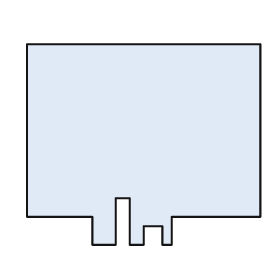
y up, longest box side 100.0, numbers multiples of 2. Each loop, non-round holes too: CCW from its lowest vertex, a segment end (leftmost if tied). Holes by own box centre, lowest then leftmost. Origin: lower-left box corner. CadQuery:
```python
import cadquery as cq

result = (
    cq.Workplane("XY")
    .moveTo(28.0, 0.0)
    .lineTo(38.0, 0.0)
    .lineTo(38.0, 20.0)
    .lineTo(44.0, 20.0)
    .lineTo(44.0, 0.0)
    .lineTo(50.0, 0.0)
    .lineTo(50.0, 8.0)
    .lineTo(58.0, 8.0)
    .lineTo(58.0, 0.0)
    .lineTo(62.0, 0.0)
    .lineTo(62.0, 12.0)
    .lineTo(100.0, 12.0)
    .lineTo(100.0, 86.0)
    .lineTo(0.0, 86.0)
    .lineTo(0.0, 12.0)
    .lineTo(28.0, 12.0)
    .close()
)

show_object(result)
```